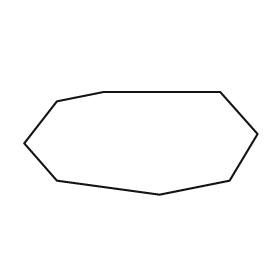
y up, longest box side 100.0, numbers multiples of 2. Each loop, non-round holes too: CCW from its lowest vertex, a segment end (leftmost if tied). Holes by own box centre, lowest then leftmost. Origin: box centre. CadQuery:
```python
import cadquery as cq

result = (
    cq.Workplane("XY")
    .moveTo(8.0, -22.0)
    .lineTo(38.0, -16.0)
    .lineTo(50.0, 4.0)
    .lineTo(34.0, 22.0)
    .lineTo(-16.0, 22.0)
    .lineTo(-36.0, 18.0)
    .lineTo(-50.0, 0.0)
    .lineTo(-36.0, -16.0)
    .close()
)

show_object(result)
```